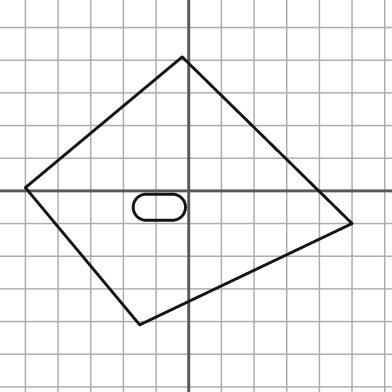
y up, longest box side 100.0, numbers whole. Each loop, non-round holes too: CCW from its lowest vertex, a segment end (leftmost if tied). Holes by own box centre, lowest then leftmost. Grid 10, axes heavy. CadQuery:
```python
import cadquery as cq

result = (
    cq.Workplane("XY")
    .moveTo(-15.0, -41.0)
    .lineTo(50.0, -10.0)
    .lineTo(-2.0, 41.0)
    .lineTo(-50.0, 1.0)
    .close()
    .moveTo(-13.0, -9.0)
    .lineTo(-5.0, -9.0)
    .threePointArc((-1.0, -5.0), (-5.0, -1.0))
    .lineTo(-13.0, -1.0)
    .threePointArc((-17.0, -5.0), (-13.0, -9.0))
    .close()
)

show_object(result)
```